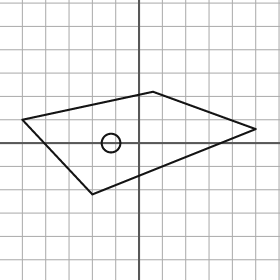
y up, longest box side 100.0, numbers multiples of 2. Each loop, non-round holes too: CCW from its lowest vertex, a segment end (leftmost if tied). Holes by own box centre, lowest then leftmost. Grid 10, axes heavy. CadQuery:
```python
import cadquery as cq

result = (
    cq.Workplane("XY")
    .moveTo(-20.0, -22.0)
    .lineTo(50.0, 6.0)
    .lineTo(6.0, 22.0)
    .lineTo(-50.0, 10.0)
    .close()
    .moveTo(-12.0, 0.0)
    .circle(4.0)
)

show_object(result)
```